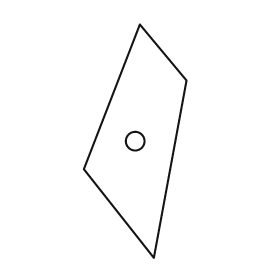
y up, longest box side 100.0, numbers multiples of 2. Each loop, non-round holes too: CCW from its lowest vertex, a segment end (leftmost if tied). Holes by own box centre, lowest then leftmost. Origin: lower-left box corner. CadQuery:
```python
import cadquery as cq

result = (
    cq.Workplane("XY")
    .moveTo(30.0, 0.0)
    .lineTo(44.0, 76.0)
    .lineTo(24.0, 100.0)
    .lineTo(0.0, 38.0)
    .close()
    .moveTo(22.0, 50.0)
    .circle(4.0)
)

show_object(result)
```